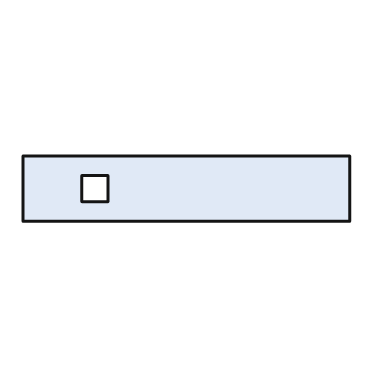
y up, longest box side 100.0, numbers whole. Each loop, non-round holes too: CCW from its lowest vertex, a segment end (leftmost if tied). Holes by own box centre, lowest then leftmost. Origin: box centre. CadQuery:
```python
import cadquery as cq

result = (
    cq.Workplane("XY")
    .moveTo(-50.0, -10.0)
    .lineTo(50.0, -10.0)
    .lineTo(50.0, 10.0)
    .lineTo(-50.0, 10.0)
    .close()
    .moveTo(-32.0, -4.0)
    .lineTo(-24.0, -4.0)
    .lineTo(-24.0, 4.0)
    .lineTo(-32.0, 4.0)
    .close()
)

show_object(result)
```